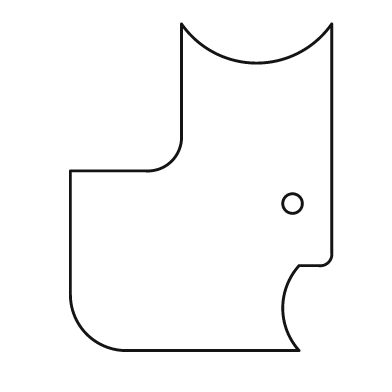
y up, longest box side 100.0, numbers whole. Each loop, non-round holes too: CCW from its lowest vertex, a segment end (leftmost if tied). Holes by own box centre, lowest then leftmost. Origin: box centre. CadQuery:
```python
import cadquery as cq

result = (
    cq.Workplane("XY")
    .moveTo(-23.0, -50.0)
    .lineTo(30.0, -50.0)
    .threePointArc((25.0, -37.0), (30.0, -24.0))
    .lineTo(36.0, -24.0)
    .threePointArc((39.0, -23.0), (40.0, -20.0))
    .lineTo(40.0, 50.0)
    .threePointArc((17.0, 38.0), (-6.0, 50.0))
    .lineTo(-6.0, 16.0)
    .threePointArc((-9.0, 8.0), (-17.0, 5.0))
    .lineTo(-40.0, 5.0)
    .lineTo(-40.0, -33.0)
    .threePointArc((-35.0, -45.0), (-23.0, -50.0))
    .close()
    .moveTo(28.0, -5.0)
    .circle(3.0)
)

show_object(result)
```